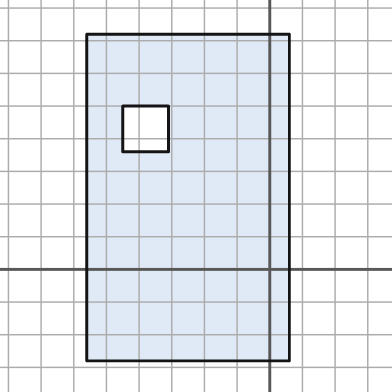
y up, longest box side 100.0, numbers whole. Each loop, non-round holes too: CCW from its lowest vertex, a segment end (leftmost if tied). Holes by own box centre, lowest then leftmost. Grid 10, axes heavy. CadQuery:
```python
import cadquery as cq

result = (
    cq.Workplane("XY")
    .moveTo(-56.0, -28.0)
    .lineTo(6.0, -28.0)
    .lineTo(6.0, 72.0)
    .lineTo(-56.0, 72.0)
    .close()
    .moveTo(-45.0, 36.0)
    .lineTo(-31.0, 36.0)
    .lineTo(-31.0, 50.0)
    .lineTo(-45.0, 50.0)
    .close()
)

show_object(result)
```